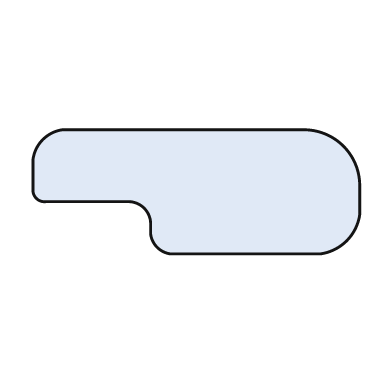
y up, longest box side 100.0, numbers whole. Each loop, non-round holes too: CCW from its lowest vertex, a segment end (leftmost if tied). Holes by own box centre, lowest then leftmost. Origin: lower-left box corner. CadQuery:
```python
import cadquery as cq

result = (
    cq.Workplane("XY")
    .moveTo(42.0, 0.0)
    .lineTo(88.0, 0.0)
    .threePointArc((96.0, 4.0), (100.0, 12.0))
    .lineTo(100.0, 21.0)
    .threePointArc((95.0, 33.0), (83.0, 38.0))
    .lineTo(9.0, 38.0)
    .threePointArc((3.0, 35.0), (0.0, 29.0))
    .lineTo(0.0, 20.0)
    .threePointArc((1.0, 17.0), (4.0, 16.0))
    .lineTo(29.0, 16.0)
    .threePointArc((34.0, 14.0), (36.0, 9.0))
    .lineTo(36.0, 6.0)
    .threePointArc((38.0, 2.0), (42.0, 0.0))
    .close()
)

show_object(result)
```